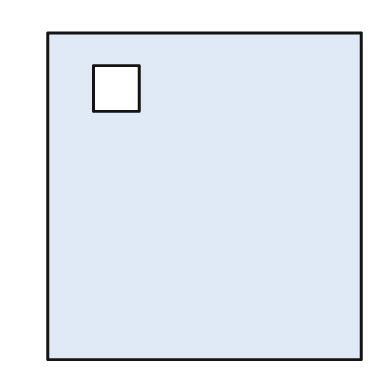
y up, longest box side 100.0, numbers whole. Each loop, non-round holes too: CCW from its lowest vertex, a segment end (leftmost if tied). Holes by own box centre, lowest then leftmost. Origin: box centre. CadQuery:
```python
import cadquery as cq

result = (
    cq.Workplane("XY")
    .moveTo(-48.0, -50.0)
    .lineTo(48.0, -50.0)
    .lineTo(48.0, 50.0)
    .lineTo(-48.0, 50.0)
    .close()
    .moveTo(-34.0, 26.0)
    .lineTo(-20.0, 26.0)
    .lineTo(-20.0, 40.0)
    .lineTo(-34.0, 40.0)
    .close()
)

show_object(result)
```